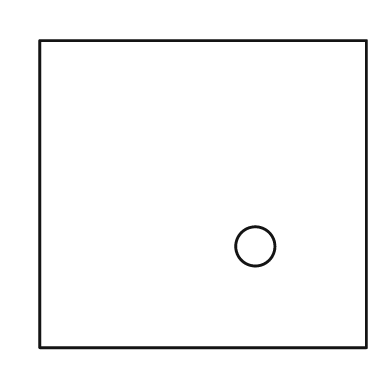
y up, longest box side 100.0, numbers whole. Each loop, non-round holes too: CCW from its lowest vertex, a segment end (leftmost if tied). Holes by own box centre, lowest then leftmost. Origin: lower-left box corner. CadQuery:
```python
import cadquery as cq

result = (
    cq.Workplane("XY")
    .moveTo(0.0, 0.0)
    .lineTo(100.0, 0.0)
    .lineTo(100.0, 94.0)
    .lineTo(0.0, 94.0)
    .close()
    .moveTo(66.0, 31.0)
    .circle(6.0)
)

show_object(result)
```